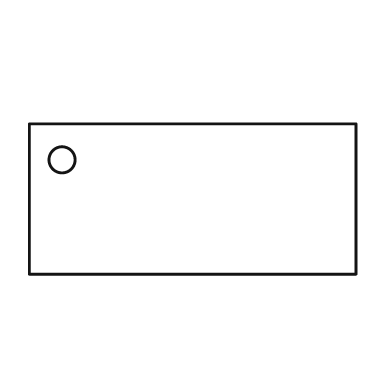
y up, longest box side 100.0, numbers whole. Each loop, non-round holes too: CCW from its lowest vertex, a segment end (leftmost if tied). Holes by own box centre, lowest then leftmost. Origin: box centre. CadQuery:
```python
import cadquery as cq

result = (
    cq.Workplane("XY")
    .moveTo(-50.0, -23.0)
    .lineTo(50.0, -23.0)
    .lineTo(50.0, 23.0)
    .lineTo(-50.0, 23.0)
    .close()
    .moveTo(-40.0, 12.0)
    .circle(4.0)
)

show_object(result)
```